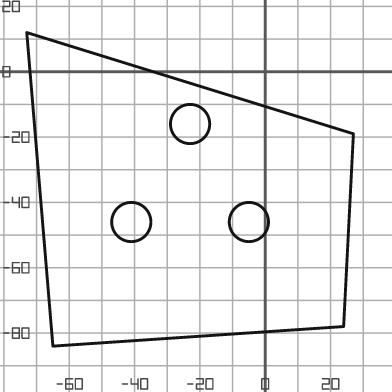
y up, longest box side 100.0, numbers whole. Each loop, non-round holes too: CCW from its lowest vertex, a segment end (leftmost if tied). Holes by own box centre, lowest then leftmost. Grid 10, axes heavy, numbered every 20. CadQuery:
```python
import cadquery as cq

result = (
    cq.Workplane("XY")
    .moveTo(-65.0, -84.0)
    .lineTo(24.0, -78.0)
    .lineTo(27.0, -19.0)
    .lineTo(-73.0, 12.0)
    .close()
    .moveTo(-41.0, -46.0)
    .circle(6.0)
    .moveTo(-5.0, -46.0)
    .circle(6.0)
    .moveTo(-23.0, -16.0)
    .circle(6.0)
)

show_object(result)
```